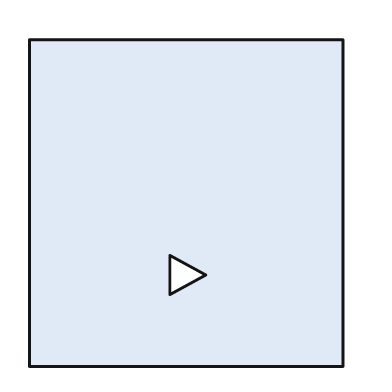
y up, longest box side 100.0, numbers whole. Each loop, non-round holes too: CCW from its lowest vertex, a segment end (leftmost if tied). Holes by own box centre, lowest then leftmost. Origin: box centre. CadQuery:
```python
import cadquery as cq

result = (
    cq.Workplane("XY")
    .moveTo(-48.0, -50.0)
    .lineTo(48.0, -50.0)
    .lineTo(48.0, 50.0)
    .lineTo(-48.0, 50.0)
    .close()
    .moveTo(-5.0, -28.0)
    .lineTo(6.0, -22.0)
    .lineTo(-5.0, -16.0)
    .close()
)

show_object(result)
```